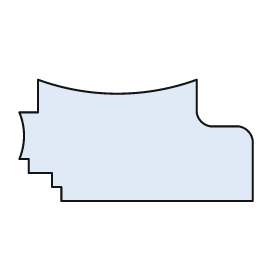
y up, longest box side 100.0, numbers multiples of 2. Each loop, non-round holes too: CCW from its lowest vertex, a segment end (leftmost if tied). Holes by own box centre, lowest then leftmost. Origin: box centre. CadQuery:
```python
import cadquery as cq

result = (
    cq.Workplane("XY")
    .moveTo(-32.0, -26.0)
    .lineTo(50.0, -26.0)
    .lineTo(50.0, 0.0)
    .threePointArc((48.0, 4.0), (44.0, 6.0))
    .lineTo(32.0, 6.0)
    .threePointArc((28.0, 8.0), (26.0, 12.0))
    .lineTo(26.0, 26.0)
    .threePointArc((-8.0, 20.0), (-42.0, 26.0))
    .lineTo(-42.0, 12.0)
    .lineTo(-50.0, 12.0)
    .threePointArc((-48.0, 2.0), (-50.0, -8.0))
    .lineTo(-46.0, -8.0)
    .lineTo(-46.0, -14.0)
    .lineTo(-36.0, -14.0)
    .lineTo(-36.0, -20.0)
    .lineTo(-32.0, -20.0)
    .close()
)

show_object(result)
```